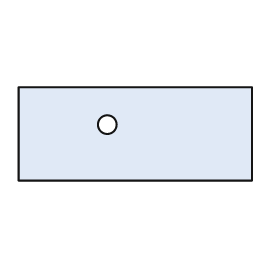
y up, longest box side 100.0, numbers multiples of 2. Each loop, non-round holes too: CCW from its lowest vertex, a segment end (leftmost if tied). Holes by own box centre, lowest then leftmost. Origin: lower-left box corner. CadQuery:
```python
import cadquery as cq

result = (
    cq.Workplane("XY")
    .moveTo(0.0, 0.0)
    .lineTo(100.0, 0.0)
    .lineTo(100.0, 40.0)
    .lineTo(0.0, 40.0)
    .close()
    .moveTo(38.0, 24.0)
    .circle(4.0)
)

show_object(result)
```